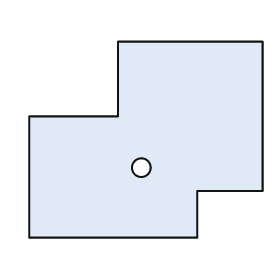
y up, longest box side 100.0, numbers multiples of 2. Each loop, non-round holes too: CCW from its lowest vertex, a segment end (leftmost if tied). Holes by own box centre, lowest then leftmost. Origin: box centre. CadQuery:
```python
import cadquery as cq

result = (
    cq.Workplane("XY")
    .moveTo(-50.0, -42.0)
    .lineTo(22.0, -42.0)
    .lineTo(22.0, -22.0)
    .lineTo(50.0, -22.0)
    .lineTo(50.0, 42.0)
    .lineTo(-12.0, 42.0)
    .lineTo(-12.0, 10.0)
    .lineTo(-50.0, 10.0)
    .close()
    .moveTo(-2.0, -12.0)
    .circle(4.0)
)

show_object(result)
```